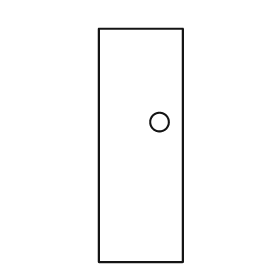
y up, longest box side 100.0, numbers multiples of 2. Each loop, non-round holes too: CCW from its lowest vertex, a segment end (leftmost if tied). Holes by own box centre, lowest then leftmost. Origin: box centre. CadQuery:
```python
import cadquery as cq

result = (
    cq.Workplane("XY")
    .moveTo(-18.0, -50.0)
    .lineTo(18.0, -50.0)
    .lineTo(18.0, 50.0)
    .lineTo(-18.0, 50.0)
    .close()
    .moveTo(8.0, 10.0)
    .circle(4.0)
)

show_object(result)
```